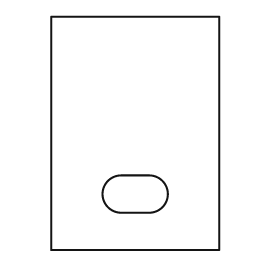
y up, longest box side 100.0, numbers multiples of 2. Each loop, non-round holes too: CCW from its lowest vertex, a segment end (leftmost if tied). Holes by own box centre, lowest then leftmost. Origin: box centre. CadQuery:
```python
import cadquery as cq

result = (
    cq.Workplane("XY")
    .moveTo(-36.0, -50.0)
    .lineTo(36.0, -50.0)
    .lineTo(36.0, 50.0)
    .lineTo(-36.0, 50.0)
    .close()
    .moveTo(-6.0, -34.0)
    .lineTo(6.0, -34.0)
    .threePointArc((14.0, -26.0), (6.0, -18.0))
    .lineTo(-6.0, -18.0)
    .threePointArc((-14.0, -26.0), (-6.0, -34.0))
    .close()
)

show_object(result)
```